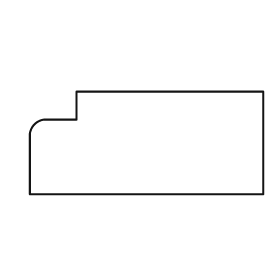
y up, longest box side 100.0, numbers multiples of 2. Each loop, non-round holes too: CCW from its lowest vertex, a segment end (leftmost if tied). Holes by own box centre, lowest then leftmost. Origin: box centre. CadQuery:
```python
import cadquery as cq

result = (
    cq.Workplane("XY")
    .moveTo(-50.0, -22.0)
    .lineTo(50.0, -22.0)
    .lineTo(50.0, 22.0)
    .lineTo(-30.0, 22.0)
    .lineTo(-30.0, 10.0)
    .lineTo(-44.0, 10.0)
    .threePointArc((-48.0, 8.0), (-50.0, 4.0))
    .close()
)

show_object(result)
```